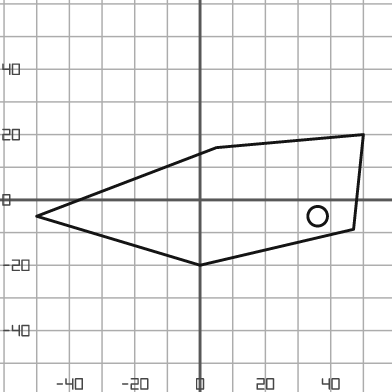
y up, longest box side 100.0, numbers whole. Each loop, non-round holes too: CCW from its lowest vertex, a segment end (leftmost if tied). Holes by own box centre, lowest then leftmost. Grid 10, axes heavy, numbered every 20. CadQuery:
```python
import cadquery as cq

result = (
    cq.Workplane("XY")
    .moveTo(0.0, -20.0)
    .lineTo(47.0, -9.0)
    .lineTo(50.0, 20.0)
    .lineTo(5.0, 16.0)
    .lineTo(-50.0, -5.0)
    .close()
    .moveTo(36.0, -5.0)
    .circle(3.0)
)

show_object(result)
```